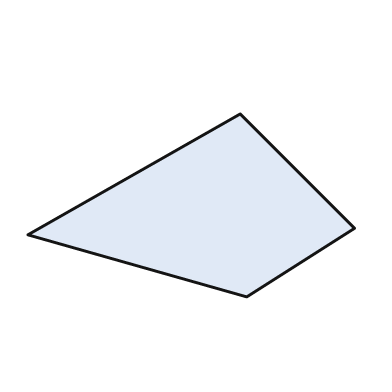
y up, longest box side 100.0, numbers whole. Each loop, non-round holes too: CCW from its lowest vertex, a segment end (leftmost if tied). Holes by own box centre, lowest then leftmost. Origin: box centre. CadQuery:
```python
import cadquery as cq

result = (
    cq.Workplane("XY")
    .moveTo(17.0, -28.0)
    .lineTo(50.0, -7.0)
    .lineTo(15.0, 28.0)
    .lineTo(-50.0, -9.0)
    .close()
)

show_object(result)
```